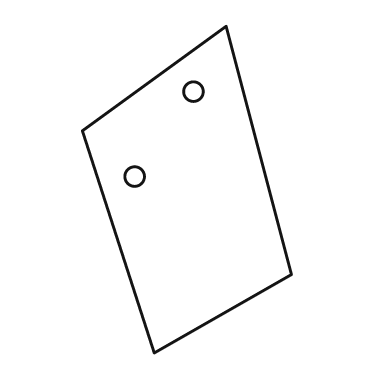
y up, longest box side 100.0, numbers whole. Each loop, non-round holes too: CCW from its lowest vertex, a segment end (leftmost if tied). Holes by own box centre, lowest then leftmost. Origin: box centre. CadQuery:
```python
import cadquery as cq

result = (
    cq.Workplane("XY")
    .moveTo(-10.0, -50.0)
    .lineTo(32.0, -26.0)
    .lineTo(12.0, 50.0)
    .lineTo(-32.0, 18.0)
    .close()
    .moveTo(-16.0, 4.0)
    .circle(3.0)
    .moveTo(2.0, 30.0)
    .circle(3.0)
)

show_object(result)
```